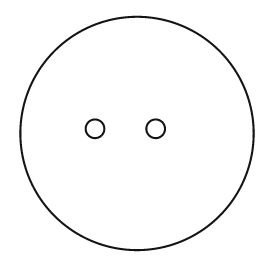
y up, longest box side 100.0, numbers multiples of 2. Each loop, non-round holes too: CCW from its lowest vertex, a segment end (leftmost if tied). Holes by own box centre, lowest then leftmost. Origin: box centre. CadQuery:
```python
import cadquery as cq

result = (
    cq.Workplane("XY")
    .moveTo(0.0, 0.0)
    .circle(50.0)
    .moveTo(-18.0, 2.0)
    .circle(4.0)
    .moveTo(8.0, 2.0)
    .circle(4.0)
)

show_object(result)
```